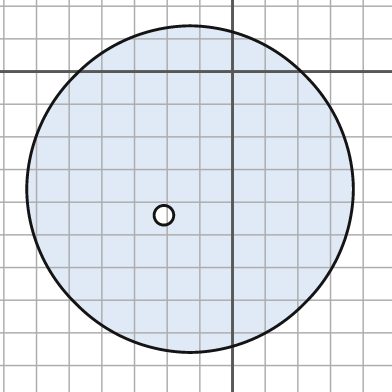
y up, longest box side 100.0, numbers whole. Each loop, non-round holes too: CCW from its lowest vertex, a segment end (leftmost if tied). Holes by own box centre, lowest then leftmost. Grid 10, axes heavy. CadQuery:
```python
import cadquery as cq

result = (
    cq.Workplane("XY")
    .moveTo(-13.0, -86.0)
    .threePointArc((6.0, -82.0), (22.0, -71.0))
    .threePointArc((33.0, -55.0), (37.0, -36.0))
    .threePointArc((33.0, -17.0), (22.0, -1.0))
    .threePointArc((6.0, 10.0), (-13.0, 14.0))
    .threePointArc((-32.0, 10.0), (-48.0, -1.0))
    .threePointArc((-59.0, -17.0), (-63.0, -36.0))
    .threePointArc((-59.0, -55.0), (-48.0, -71.0))
    .threePointArc((-32.0, -82.0), (-13.0, -86.0))
    .close()
    .moveTo(-21.0, -44.0)
    .circle(3.0)
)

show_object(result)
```